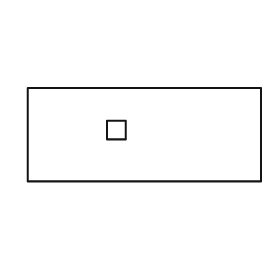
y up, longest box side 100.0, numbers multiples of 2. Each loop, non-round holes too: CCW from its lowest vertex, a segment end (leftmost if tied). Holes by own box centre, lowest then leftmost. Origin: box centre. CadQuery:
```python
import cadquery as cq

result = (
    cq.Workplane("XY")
    .moveTo(-50.0, -20.0)
    .lineTo(50.0, -20.0)
    .lineTo(50.0, 20.0)
    .lineTo(-50.0, 20.0)
    .close()
    .moveTo(-16.0, -2.0)
    .lineTo(-8.0, -2.0)
    .lineTo(-8.0, 6.0)
    .lineTo(-16.0, 6.0)
    .close()
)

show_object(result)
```